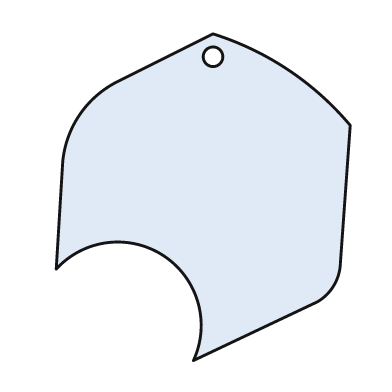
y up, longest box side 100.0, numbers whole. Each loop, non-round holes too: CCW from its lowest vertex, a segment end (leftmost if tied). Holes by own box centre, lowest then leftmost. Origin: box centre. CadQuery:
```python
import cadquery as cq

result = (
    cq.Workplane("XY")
    .moveTo(-3.0, -50.0)
    .lineTo(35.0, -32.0)
    .threePointArc((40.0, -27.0), (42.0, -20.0))
    .lineTo(45.0, 22.0)
    .threePointArc((26.0, 39.0), (3.0, 50.0))
    .lineTo(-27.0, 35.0)
    .threePointArc((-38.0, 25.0), (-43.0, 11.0))
    .lineTo(-45.0, -22.0)
    .threePointArc((-12.0, -18.0), (-3.0, -50.0))
    .close()
    .moveTo(3.0, 43.0)
    .circle(3.0)
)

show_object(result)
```